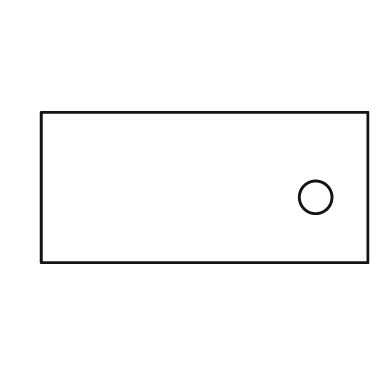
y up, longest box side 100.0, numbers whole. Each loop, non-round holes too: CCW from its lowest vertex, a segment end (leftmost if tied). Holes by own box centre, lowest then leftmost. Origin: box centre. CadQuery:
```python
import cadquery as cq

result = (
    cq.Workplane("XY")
    .moveTo(-50.0, -23.0)
    .lineTo(50.0, -23.0)
    .lineTo(50.0, 23.0)
    .lineTo(-50.0, 23.0)
    .close()
    .moveTo(34.0, -3.0)
    .circle(5.0)
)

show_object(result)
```